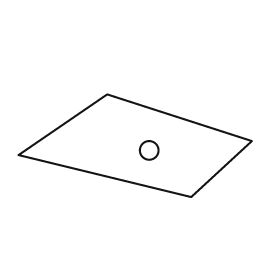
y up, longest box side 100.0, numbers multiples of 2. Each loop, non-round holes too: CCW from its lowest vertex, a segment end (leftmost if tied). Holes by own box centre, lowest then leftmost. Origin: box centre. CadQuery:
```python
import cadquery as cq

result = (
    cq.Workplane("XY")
    .moveTo(24.0, -22.0)
    .lineTo(50.0, 2.0)
    .lineTo(-12.0, 22.0)
    .lineTo(-50.0, -4.0)
    .close()
    .moveTo(6.0, -2.0)
    .circle(4.0)
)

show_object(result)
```